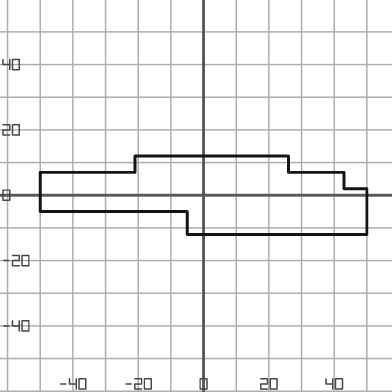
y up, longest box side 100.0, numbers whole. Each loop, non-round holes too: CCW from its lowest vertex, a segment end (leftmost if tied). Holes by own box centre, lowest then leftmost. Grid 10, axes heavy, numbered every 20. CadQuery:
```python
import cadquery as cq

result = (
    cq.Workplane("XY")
    .moveTo(-5.0, -12.0)
    .lineTo(50.0, -12.0)
    .lineTo(50.0, 2.0)
    .lineTo(43.0, 2.0)
    .lineTo(43.0, 7.0)
    .lineTo(26.0, 7.0)
    .lineTo(26.0, 12.0)
    .lineTo(-21.0, 12.0)
    .lineTo(-21.0, 7.0)
    .lineTo(-50.0, 7.0)
    .lineTo(-50.0, -5.0)
    .lineTo(-5.0, -5.0)
    .close()
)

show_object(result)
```